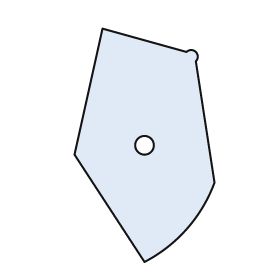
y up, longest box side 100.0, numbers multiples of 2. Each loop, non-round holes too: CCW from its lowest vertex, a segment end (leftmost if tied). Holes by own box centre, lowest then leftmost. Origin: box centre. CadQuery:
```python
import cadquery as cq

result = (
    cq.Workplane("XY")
    .moveTo(0.0, -50.0)
    .threePointArc((18.0, -36.0), (30.0, -16.0))
    .lineTo(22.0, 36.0)
    .threePointArc((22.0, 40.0), (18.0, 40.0))
    .lineTo(-18.0, 50.0)
    .lineTo(-30.0, -4.0)
    .close()
    .moveTo(0.0, 0.0)
    .circle(4.0)
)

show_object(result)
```